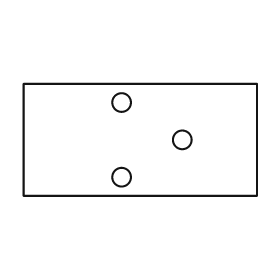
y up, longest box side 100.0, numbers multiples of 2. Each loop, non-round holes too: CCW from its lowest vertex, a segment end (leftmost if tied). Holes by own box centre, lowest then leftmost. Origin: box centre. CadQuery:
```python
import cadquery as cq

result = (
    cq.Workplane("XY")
    .moveTo(-50.0, -24.0)
    .lineTo(50.0, -24.0)
    .lineTo(50.0, 24.0)
    .lineTo(-50.0, 24.0)
    .close()
    .moveTo(-8.0, -16.0)
    .circle(4.0)
    .moveTo(18.0, 0.0)
    .circle(4.0)
    .moveTo(-8.0, 16.0)
    .circle(4.0)
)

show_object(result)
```